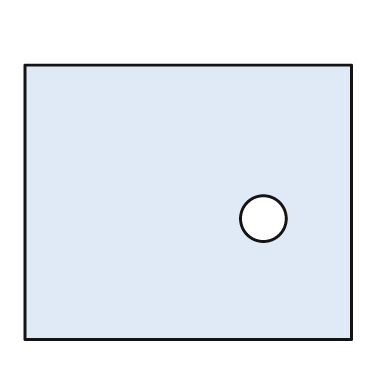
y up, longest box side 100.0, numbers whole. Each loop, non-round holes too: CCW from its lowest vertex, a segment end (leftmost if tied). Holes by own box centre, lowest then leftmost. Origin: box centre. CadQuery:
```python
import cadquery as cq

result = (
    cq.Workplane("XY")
    .moveTo(-50.0, -42.0)
    .lineTo(50.0, -42.0)
    .lineTo(50.0, 42.0)
    .lineTo(-50.0, 42.0)
    .close()
    .moveTo(23.0, -5.0)
    .circle(7.0)
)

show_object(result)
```